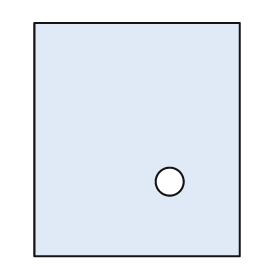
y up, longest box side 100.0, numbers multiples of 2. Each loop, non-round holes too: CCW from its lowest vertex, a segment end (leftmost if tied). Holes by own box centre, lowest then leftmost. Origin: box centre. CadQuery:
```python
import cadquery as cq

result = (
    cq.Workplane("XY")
    .moveTo(-44.0, -50.0)
    .lineTo(44.0, -50.0)
    .lineTo(44.0, 50.0)
    .lineTo(-44.0, 50.0)
    .close()
    .moveTo(14.0, -18.0)
    .circle(6.0)
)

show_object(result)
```